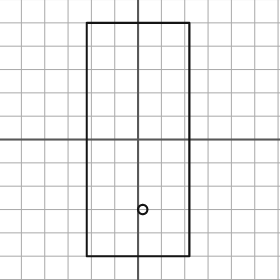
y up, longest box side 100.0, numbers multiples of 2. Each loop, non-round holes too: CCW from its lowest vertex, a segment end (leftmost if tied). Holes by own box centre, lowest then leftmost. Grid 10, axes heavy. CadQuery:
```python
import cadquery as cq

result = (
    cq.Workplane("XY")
    .moveTo(-22.0, -50.0)
    .lineTo(22.0, -50.0)
    .lineTo(22.0, 50.0)
    .lineTo(-22.0, 50.0)
    .close()
    .moveTo(2.0, -30.0)
    .circle(2.0)
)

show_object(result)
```